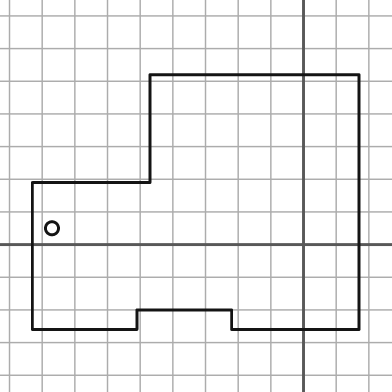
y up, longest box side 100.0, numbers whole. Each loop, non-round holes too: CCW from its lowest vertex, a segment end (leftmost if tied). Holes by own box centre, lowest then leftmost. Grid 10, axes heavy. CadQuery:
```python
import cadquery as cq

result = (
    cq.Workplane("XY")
    .moveTo(-83.0, -26.0)
    .lineTo(-51.0, -26.0)
    .lineTo(-51.0, -20.0)
    .lineTo(-22.0, -20.0)
    .lineTo(-22.0, -26.0)
    .lineTo(17.0, -26.0)
    .lineTo(17.0, 52.0)
    .lineTo(-47.0, 52.0)
    .lineTo(-47.0, 19.0)
    .lineTo(-83.0, 19.0)
    .close()
    .moveTo(-77.0, 5.0)
    .circle(2.0)
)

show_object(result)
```